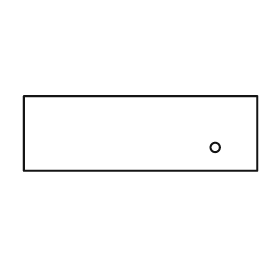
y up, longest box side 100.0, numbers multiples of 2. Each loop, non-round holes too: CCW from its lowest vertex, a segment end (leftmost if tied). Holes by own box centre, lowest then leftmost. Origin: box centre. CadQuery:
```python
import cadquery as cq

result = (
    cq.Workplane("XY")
    .moveTo(-50.0, -16.0)
    .lineTo(50.0, -16.0)
    .lineTo(50.0, 16.0)
    .lineTo(-50.0, 16.0)
    .close()
    .moveTo(32.0, -6.0)
    .circle(2.0)
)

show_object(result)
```